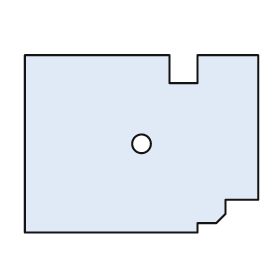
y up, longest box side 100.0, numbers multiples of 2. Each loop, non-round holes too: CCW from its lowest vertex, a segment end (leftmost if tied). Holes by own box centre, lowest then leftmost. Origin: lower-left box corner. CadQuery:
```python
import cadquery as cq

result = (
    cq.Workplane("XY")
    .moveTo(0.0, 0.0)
    .lineTo(74.0, 0.0)
    .lineTo(74.0, 4.0)
    .lineTo(82.0, 4.0)
    .lineTo(86.0, 8.0)
    .lineTo(86.0, 14.0)
    .lineTo(100.0, 14.0)
    .lineTo(100.0, 76.0)
    .lineTo(74.0, 76.0)
    .lineTo(74.0, 64.0)
    .lineTo(62.0, 64.0)
    .lineTo(62.0, 76.0)
    .lineTo(0.0, 76.0)
    .close()
    .moveTo(50.0, 38.0)
    .circle(4.0)
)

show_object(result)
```